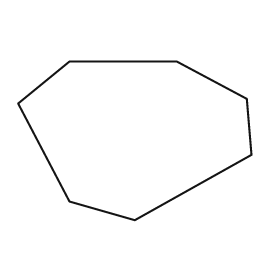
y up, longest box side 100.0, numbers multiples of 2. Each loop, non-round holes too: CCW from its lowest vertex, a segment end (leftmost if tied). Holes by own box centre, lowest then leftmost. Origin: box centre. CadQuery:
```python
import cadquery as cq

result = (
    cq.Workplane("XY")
    .moveTo(0.0, -34.0)
    .lineTo(50.0, -6.0)
    .lineTo(48.0, 18.0)
    .lineTo(18.0, 34.0)
    .lineTo(-28.0, 34.0)
    .lineTo(-50.0, 16.0)
    .lineTo(-28.0, -26.0)
    .close()
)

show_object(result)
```